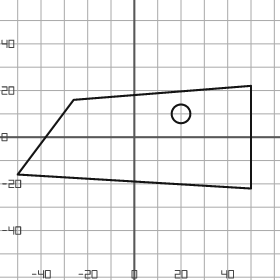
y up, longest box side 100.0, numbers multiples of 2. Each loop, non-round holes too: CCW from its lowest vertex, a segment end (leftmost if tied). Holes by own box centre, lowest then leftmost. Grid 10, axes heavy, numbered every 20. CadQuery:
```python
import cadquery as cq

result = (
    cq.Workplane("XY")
    .moveTo(50.0, -22.0)
    .lineTo(50.0, 22.0)
    .lineTo(-26.0, 16.0)
    .lineTo(-50.0, -16.0)
    .close()
    .moveTo(20.0, 10.0)
    .circle(4.0)
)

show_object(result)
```